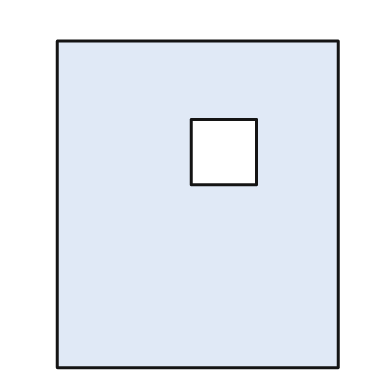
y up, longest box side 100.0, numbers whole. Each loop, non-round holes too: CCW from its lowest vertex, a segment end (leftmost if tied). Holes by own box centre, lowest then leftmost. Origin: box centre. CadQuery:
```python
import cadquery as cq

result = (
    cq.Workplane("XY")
    .moveTo(-43.0, -50.0)
    .lineTo(43.0, -50.0)
    .lineTo(43.0, 50.0)
    .lineTo(-43.0, 50.0)
    .close()
    .moveTo(-2.0, 6.0)
    .lineTo(18.0, 6.0)
    .lineTo(18.0, 26.0)
    .lineTo(-2.0, 26.0)
    .close()
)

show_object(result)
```